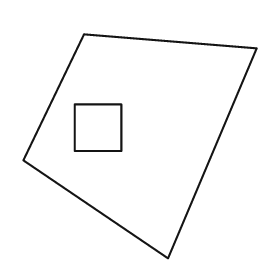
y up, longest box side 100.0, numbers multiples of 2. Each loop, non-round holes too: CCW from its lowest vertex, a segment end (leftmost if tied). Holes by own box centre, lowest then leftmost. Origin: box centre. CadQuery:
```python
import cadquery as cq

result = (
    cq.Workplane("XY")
    .moveTo(12.0, -48.0)
    .lineTo(50.0, 42.0)
    .lineTo(-24.0, 48.0)
    .lineTo(-50.0, -6.0)
    .close()
    .moveTo(-28.0, -2.0)
    .lineTo(-8.0, -2.0)
    .lineTo(-8.0, 18.0)
    .lineTo(-28.0, 18.0)
    .close()
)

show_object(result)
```